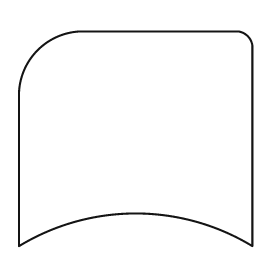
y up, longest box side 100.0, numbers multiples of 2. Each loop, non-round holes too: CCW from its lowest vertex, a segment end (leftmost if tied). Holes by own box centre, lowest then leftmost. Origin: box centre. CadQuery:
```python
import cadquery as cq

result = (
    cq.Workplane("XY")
    .moveTo(-50.0, -46.0)
    .threePointArc((0.0, -32.0), (50.0, -46.0))
    .lineTo(50.0, 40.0)
    .threePointArc((48.0, 44.0), (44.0, 46.0))
    .lineTo(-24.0, 46.0)
    .threePointArc((-42.0, 38.0), (-50.0, 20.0))
    .close()
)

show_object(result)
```